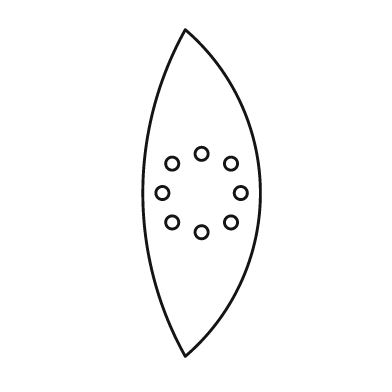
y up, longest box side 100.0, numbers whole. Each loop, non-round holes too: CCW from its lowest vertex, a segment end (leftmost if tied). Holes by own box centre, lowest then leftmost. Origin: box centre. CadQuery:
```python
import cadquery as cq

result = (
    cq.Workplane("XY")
    .moveTo(-5.0, -50.0)
    .threePointArc((18.0, 0.0), (-5.0, 50.0))
    .threePointArc((-18.0, 0.0), (-5.0, -50.0))
    .close()
    .moveTo(0.0, -12.0)
    .circle(2.0)
    .moveTo(-9.0, -9.0)
    .circle(2.0)
    .moveTo(9.0, -9.0)
    .circle(2.0)
    .moveTo(-12.0, 0.0)
    .circle(2.0)
    .moveTo(12.0, 0.0)
    .circle(2.0)
    .moveTo(-9.0, 9.0)
    .circle(2.0)
    .moveTo(9.0, 9.0)
    .circle(2.0)
    .moveTo(0.0, 12.0)
    .circle(2.0)
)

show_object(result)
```